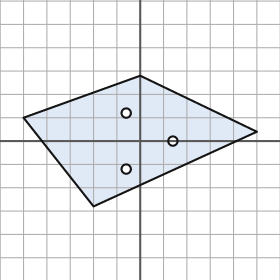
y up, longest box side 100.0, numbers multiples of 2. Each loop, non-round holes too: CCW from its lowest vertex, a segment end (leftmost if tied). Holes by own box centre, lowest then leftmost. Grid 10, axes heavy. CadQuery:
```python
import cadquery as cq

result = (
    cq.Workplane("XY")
    .moveTo(-20.0, -28.0)
    .lineTo(50.0, 4.0)
    .lineTo(0.0, 28.0)
    .lineTo(-50.0, 10.0)
    .close()
    .moveTo(-6.0, -12.0)
    .circle(2.0)
    .moveTo(14.0, 0.0)
    .circle(2.0)
    .moveTo(-6.0, 12.0)
    .circle(2.0)
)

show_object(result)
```